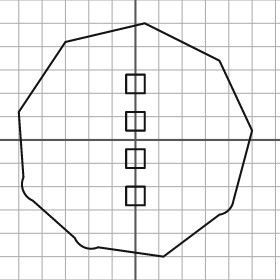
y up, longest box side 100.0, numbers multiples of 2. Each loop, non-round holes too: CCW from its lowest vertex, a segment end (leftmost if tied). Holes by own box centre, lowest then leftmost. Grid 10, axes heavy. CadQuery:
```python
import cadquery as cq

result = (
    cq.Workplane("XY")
    .moveTo(12.0, -50.0)
    .lineTo(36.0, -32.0)
    .threePointArc((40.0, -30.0), (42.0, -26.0))
    .lineTo(50.0, 4.0)
    .lineTo(36.0, 34.0)
    .lineTo(4.0, 50.0)
    .lineTo(-30.0, 42.0)
    .lineTo(-50.0, 12.0)
    .lineTo(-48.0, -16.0)
    .threePointArc((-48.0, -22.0), (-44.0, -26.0))
    .lineTo(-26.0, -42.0)
    .threePointArc((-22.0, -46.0), (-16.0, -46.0))
    .close()
    .moveTo(-4.0, -28.0)
    .lineTo(4.0, -28.0)
    .lineTo(4.0, -20.0)
    .lineTo(-4.0, -20.0)
    .close()
    .moveTo(-4.0, -12.0)
    .lineTo(4.0, -12.0)
    .lineTo(4.0, -4.0)
    .lineTo(-4.0, -4.0)
    .close()
    .moveTo(-4.0, 4.0)
    .lineTo(4.0, 4.0)
    .lineTo(4.0, 12.0)
    .lineTo(-4.0, 12.0)
    .close()
    .moveTo(-4.0, 20.0)
    .lineTo(4.0, 20.0)
    .lineTo(4.0, 28.0)
    .lineTo(-4.0, 28.0)
    .close()
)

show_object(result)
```